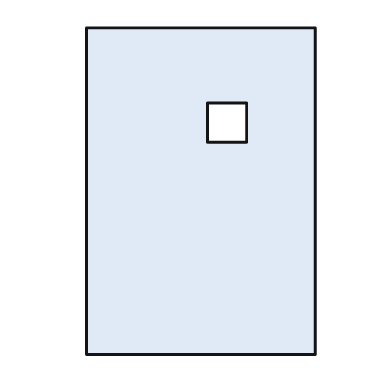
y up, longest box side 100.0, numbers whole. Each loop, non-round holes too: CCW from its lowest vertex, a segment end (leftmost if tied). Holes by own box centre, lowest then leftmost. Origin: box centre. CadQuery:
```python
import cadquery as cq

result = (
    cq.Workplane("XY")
    .moveTo(-35.0, -50.0)
    .lineTo(35.0, -50.0)
    .lineTo(35.0, 50.0)
    .lineTo(-35.0, 50.0)
    .close()
    .moveTo(2.0, 15.0)
    .lineTo(14.0, 15.0)
    .lineTo(14.0, 27.0)
    .lineTo(2.0, 27.0)
    .close()
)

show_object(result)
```